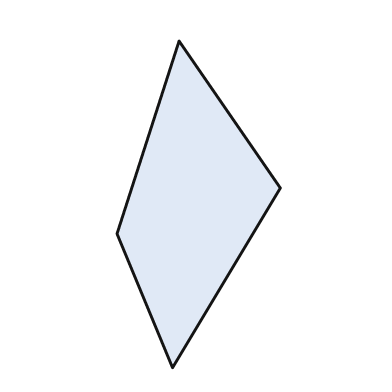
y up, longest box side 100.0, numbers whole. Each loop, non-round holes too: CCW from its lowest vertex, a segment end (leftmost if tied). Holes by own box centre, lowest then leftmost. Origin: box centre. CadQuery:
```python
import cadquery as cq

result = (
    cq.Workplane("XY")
    .moveTo(-8.0, -50.0)
    .lineTo(25.0, 5.0)
    .lineTo(-6.0, 50.0)
    .lineTo(-25.0, -9.0)
    .close()
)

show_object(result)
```